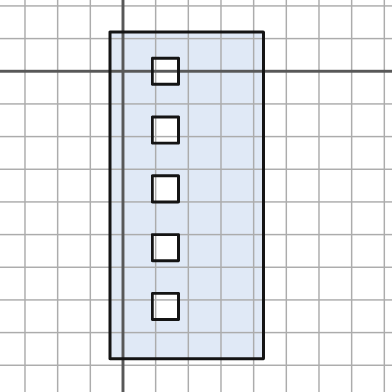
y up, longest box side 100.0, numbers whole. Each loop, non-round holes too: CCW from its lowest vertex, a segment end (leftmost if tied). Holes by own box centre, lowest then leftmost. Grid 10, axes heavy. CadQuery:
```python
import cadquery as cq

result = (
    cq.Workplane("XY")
    .moveTo(-4.0, -88.0)
    .lineTo(43.0, -88.0)
    .lineTo(43.0, 12.0)
    .lineTo(-4.0, 12.0)
    .close()
    .moveTo(9.0, -76.0)
    .lineTo(17.0, -76.0)
    .lineTo(17.0, -68.0)
    .lineTo(9.0, -68.0)
    .close()
    .moveTo(9.0, -58.0)
    .lineTo(17.0, -58.0)
    .lineTo(17.0, -50.0)
    .lineTo(9.0, -50.0)
    .close()
    .moveTo(9.0, -40.0)
    .lineTo(17.0, -40.0)
    .lineTo(17.0, -32.0)
    .lineTo(9.0, -32.0)
    .close()
    .moveTo(9.0, -22.0)
    .lineTo(17.0, -22.0)
    .lineTo(17.0, -14.0)
    .lineTo(9.0, -14.0)
    .close()
    .moveTo(9.0, -4.0)
    .lineTo(17.0, -4.0)
    .lineTo(17.0, 4.0)
    .lineTo(9.0, 4.0)
    .close()
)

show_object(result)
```